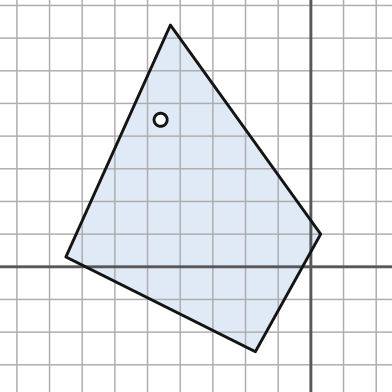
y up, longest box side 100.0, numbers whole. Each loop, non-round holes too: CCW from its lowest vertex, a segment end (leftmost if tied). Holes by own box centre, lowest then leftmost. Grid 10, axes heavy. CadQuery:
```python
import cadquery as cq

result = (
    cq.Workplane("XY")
    .moveTo(-17.0, -26.0)
    .lineTo(3.0, 10.0)
    .lineTo(-43.0, 74.0)
    .lineTo(-75.0, 3.0)
    .close()
    .moveTo(-46.0, 45.0)
    .circle(2.0)
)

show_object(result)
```